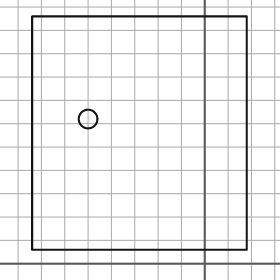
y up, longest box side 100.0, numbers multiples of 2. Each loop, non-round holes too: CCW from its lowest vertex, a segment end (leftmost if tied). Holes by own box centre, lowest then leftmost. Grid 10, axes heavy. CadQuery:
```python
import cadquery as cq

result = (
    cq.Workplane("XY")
    .moveTo(-74.0, 6.0)
    .lineTo(18.0, 6.0)
    .lineTo(18.0, 106.0)
    .lineTo(-74.0, 106.0)
    .close()
    .moveTo(-50.0, 62.0)
    .circle(4.0)
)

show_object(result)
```